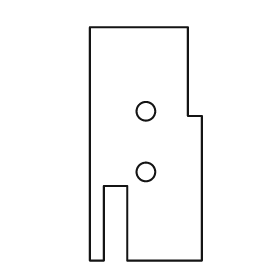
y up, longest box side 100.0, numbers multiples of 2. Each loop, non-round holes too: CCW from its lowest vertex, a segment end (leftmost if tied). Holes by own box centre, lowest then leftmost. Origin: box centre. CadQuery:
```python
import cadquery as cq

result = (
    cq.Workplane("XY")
    .moveTo(-24.0, -50.0)
    .lineTo(-18.0, -50.0)
    .lineTo(-18.0, -18.0)
    .lineTo(-8.0, -18.0)
    .lineTo(-8.0, -50.0)
    .lineTo(24.0, -50.0)
    .lineTo(24.0, 12.0)
    .lineTo(18.0, 12.0)
    .lineTo(18.0, 50.0)
    .lineTo(-24.0, 50.0)
    .close()
    .moveTo(0.0, -12.0)
    .circle(4.0)
    .moveTo(0.0, 14.0)
    .circle(4.0)
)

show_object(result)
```